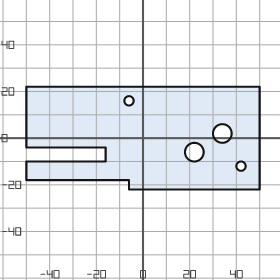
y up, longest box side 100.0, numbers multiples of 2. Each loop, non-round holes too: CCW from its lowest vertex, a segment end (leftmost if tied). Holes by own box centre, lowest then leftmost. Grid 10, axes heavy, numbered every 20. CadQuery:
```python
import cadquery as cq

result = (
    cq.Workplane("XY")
    .moveTo(-6.0, -22.0)
    .lineTo(50.0, -22.0)
    .lineTo(50.0, 22.0)
    .lineTo(-50.0, 22.0)
    .lineTo(-50.0, -4.0)
    .lineTo(-16.0, -4.0)
    .lineTo(-16.0, -10.0)
    .lineTo(-50.0, -10.0)
    .lineTo(-50.0, -18.0)
    .lineTo(-6.0, -18.0)
    .close()
    .moveTo(42.0, -12.0)
    .circle(2.0)
    .moveTo(22.0, -6.0)
    .circle(4.0)
    .moveTo(34.0, 2.0)
    .circle(4.0)
    .moveTo(-6.0, 16.0)
    .circle(2.0)
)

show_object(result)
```